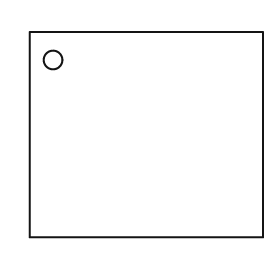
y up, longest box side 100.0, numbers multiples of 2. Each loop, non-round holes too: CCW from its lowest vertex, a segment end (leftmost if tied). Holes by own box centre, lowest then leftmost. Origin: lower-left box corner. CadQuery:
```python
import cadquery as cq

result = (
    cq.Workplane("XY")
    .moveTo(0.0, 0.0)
    .lineTo(100.0, 0.0)
    .lineTo(100.0, 88.0)
    .lineTo(0.0, 88.0)
    .close()
    .moveTo(10.0, 76.0)
    .circle(4.0)
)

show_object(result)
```